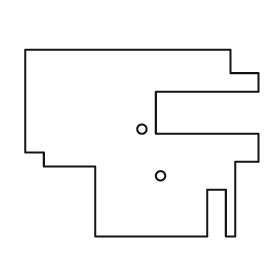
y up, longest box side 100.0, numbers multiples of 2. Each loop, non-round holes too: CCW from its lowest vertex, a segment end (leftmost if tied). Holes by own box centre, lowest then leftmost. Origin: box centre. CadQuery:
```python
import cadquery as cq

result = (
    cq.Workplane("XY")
    .moveTo(-20.0, -40.0)
    .lineTo(28.0, -40.0)
    .lineTo(28.0, -20.0)
    .lineTo(36.0, -20.0)
    .lineTo(36.0, -40.0)
    .lineTo(40.0, -40.0)
    .lineTo(40.0, -8.0)
    .lineTo(50.0, -8.0)
    .lineTo(50.0, 4.0)
    .lineTo(6.0, 4.0)
    .lineTo(6.0, 22.0)
    .lineTo(50.0, 22.0)
    .lineTo(50.0, 30.0)
    .lineTo(38.0, 30.0)
    .lineTo(38.0, 40.0)
    .lineTo(-50.0, 40.0)
    .lineTo(-50.0, -4.0)
    .lineTo(-42.0, -4.0)
    .lineTo(-42.0, -10.0)
    .lineTo(-20.0, -10.0)
    .close()
    .moveTo(8.0, -14.0)
    .circle(2.0)
    .moveTo(0.0, 6.0)
    .circle(2.0)
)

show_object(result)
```